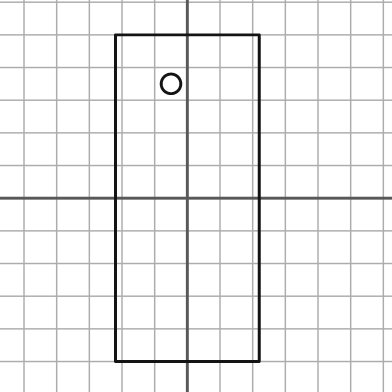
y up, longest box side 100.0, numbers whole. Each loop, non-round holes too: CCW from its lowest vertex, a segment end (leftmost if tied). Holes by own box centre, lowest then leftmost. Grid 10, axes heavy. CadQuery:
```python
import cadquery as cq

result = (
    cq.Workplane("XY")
    .moveTo(-22.0, -50.0)
    .lineTo(22.0, -50.0)
    .lineTo(22.0, 50.0)
    .lineTo(-22.0, 50.0)
    .close()
    .moveTo(-5.0, 35.0)
    .circle(3.0)
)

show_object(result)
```